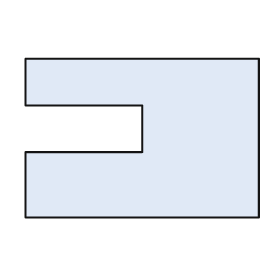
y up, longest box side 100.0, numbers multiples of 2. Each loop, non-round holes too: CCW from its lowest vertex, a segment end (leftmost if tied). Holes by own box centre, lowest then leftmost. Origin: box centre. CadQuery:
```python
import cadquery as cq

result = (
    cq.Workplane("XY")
    .moveTo(-50.0, -34.0)
    .lineTo(50.0, -34.0)
    .lineTo(50.0, 34.0)
    .lineTo(-50.0, 34.0)
    .lineTo(-50.0, 14.0)
    .lineTo(0.0, 14.0)
    .lineTo(0.0, -6.0)
    .lineTo(-50.0, -6.0)
    .close()
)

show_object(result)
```